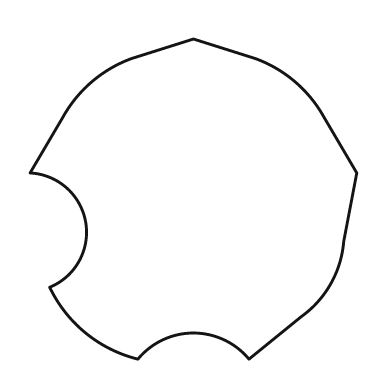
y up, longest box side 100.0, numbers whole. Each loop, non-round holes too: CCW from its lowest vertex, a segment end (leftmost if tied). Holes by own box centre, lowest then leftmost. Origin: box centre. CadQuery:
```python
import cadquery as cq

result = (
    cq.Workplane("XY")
    .moveTo(-17.0, -49.0)
    .threePointArc((0.0, -41.0), (17.0, -49.0))
    .lineTo(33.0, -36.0)
    .threePointArc((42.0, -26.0), (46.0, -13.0))
    .lineTo(50.0, 8.0)
    .lineTo(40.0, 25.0)
    .threePointArc((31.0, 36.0), (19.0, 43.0))
    .lineTo(0.0, 49.0)
    .lineTo(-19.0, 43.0)
    .threePointArc((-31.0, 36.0), (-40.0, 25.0))
    .lineTo(-50.0, 8.0)
    .threePointArc((-33.0, -7.0), (-44.0, -27.0))
    .threePointArc((-33.0, -41.0), (-17.0, -49.0))
    .close()
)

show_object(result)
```